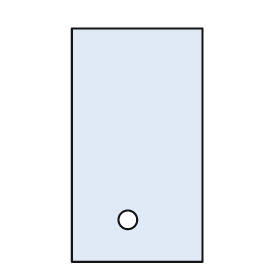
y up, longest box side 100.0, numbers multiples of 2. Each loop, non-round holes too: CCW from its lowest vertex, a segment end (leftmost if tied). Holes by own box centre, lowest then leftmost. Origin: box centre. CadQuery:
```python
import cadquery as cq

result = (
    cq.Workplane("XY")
    .moveTo(-28.0, -50.0)
    .lineTo(28.0, -50.0)
    .lineTo(28.0, 50.0)
    .lineTo(-28.0, 50.0)
    .close()
    .moveTo(-4.0, -32.0)
    .circle(4.0)
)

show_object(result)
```